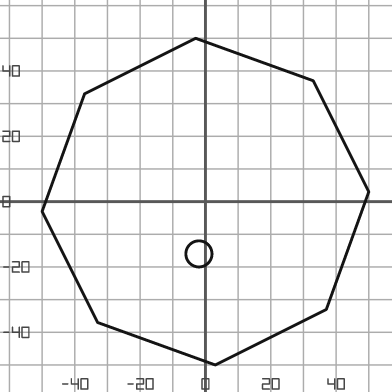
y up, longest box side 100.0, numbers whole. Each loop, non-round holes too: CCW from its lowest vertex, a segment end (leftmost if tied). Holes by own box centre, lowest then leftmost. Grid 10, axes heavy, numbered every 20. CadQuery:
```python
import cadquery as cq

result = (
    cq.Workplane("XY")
    .moveTo(3.0, -50.0)
    .lineTo(37.0, -33.0)
    .lineTo(50.0, 3.0)
    .lineTo(33.0, 37.0)
    .lineTo(-3.0, 50.0)
    .lineTo(-37.0, 33.0)
    .lineTo(-50.0, -3.0)
    .lineTo(-33.0, -37.0)
    .close()
    .moveTo(-2.0, -16.0)
    .circle(4.0)
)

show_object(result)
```